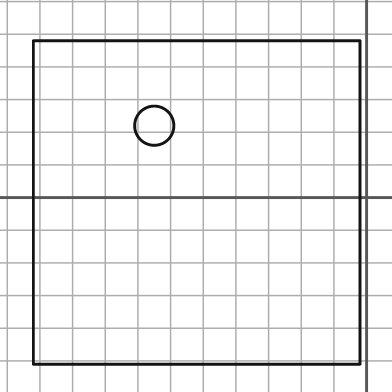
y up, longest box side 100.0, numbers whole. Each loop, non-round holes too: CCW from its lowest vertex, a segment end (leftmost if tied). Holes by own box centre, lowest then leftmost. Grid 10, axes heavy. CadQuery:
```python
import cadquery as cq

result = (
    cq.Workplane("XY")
    .moveTo(-102.0, -51.0)
    .lineTo(-2.0, -51.0)
    .lineTo(-2.0, 48.0)
    .lineTo(-102.0, 48.0)
    .close()
    .moveTo(-65.0, 22.0)
    .circle(6.0)
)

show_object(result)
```